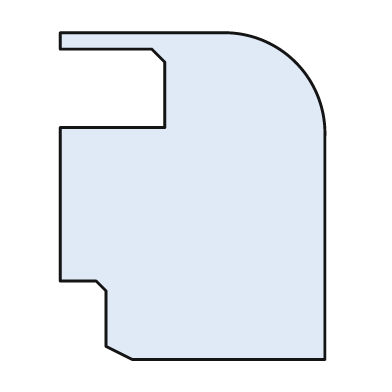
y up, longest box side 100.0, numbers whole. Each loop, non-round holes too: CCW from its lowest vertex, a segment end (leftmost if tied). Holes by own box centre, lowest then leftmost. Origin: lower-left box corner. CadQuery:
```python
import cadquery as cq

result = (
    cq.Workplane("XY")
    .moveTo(22.0, 0.0)
    .lineTo(81.0, 0.0)
    .lineTo(81.0, 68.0)
    .threePointArc((72.0, 91.0), (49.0, 100.0))
    .lineTo(0.0, 100.0)
    .lineTo(0.0, 95.0)
    .lineTo(28.0, 95.0)
    .lineTo(32.0, 91.0)
    .lineTo(32.0, 71.0)
    .lineTo(0.0, 71.0)
    .lineTo(0.0, 24.0)
    .lineTo(11.0, 24.0)
    .lineTo(14.0, 21.0)
    .lineTo(14.0, 4.0)
    .close()
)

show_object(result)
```